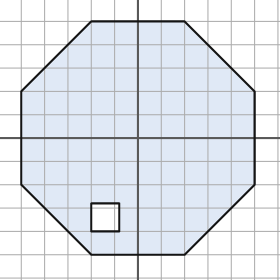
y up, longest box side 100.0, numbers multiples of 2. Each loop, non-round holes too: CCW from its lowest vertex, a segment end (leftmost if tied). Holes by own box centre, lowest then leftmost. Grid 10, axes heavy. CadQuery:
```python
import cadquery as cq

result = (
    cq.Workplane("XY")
    .moveTo(-20.0, -50.0)
    .lineTo(20.0, -50.0)
    .lineTo(50.0, -20.0)
    .lineTo(50.0, 20.0)
    .lineTo(20.0, 50.0)
    .lineTo(-20.0, 50.0)
    .lineTo(-50.0, 20.0)
    .lineTo(-50.0, -20.0)
    .close()
    .moveTo(-20.0, -40.0)
    .lineTo(-8.0, -40.0)
    .lineTo(-8.0, -28.0)
    .lineTo(-20.0, -28.0)
    .close()
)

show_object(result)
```